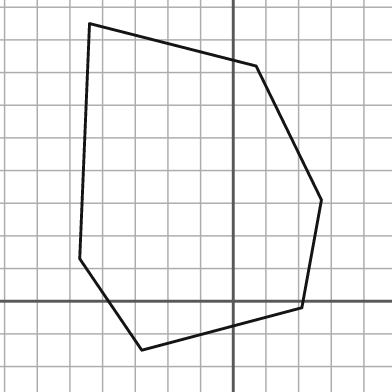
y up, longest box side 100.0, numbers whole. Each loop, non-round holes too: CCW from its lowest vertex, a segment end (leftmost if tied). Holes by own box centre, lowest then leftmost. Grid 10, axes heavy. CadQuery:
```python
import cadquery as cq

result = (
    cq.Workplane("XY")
    .moveTo(-28.0, -15.0)
    .lineTo(21.0, -2.0)
    .lineTo(27.0, 31.0)
    .lineTo(7.0, 72.0)
    .lineTo(-44.0, 85.0)
    .lineTo(-47.0, 13.0)
    .close()
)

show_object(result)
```